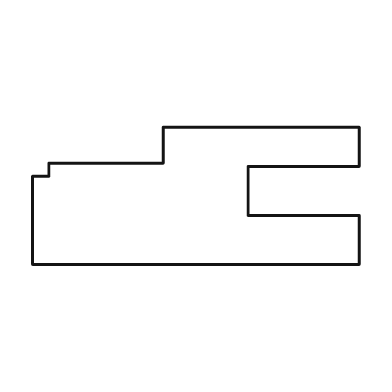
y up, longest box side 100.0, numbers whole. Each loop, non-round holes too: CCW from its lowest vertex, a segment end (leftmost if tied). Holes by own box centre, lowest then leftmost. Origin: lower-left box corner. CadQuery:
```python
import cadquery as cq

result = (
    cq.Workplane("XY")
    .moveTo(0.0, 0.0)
    .lineTo(100.0, 0.0)
    .lineTo(100.0, 15.0)
    .lineTo(66.0, 15.0)
    .lineTo(66.0, 30.0)
    .lineTo(100.0, 30.0)
    .lineTo(100.0, 42.0)
    .lineTo(40.0, 42.0)
    .lineTo(40.0, 31.0)
    .lineTo(5.0, 31.0)
    .lineTo(5.0, 27.0)
    .lineTo(0.0, 27.0)
    .close()
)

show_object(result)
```